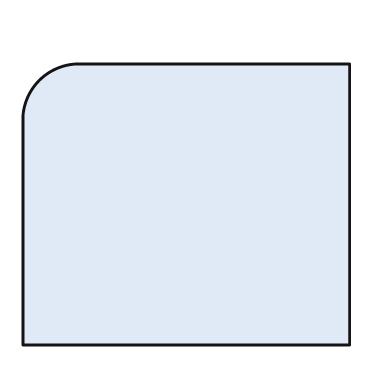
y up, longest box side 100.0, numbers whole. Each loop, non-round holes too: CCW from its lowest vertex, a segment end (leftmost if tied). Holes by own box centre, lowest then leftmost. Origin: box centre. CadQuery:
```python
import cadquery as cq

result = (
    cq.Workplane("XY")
    .moveTo(-50.0, -43.0)
    .lineTo(50.0, -43.0)
    .lineTo(50.0, 43.0)
    .lineTo(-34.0, 43.0)
    .threePointArc((-45.0, 38.0), (-50.0, 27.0))
    .close()
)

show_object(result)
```